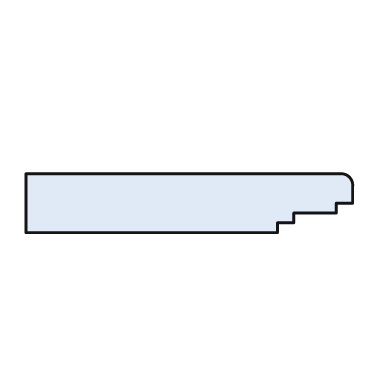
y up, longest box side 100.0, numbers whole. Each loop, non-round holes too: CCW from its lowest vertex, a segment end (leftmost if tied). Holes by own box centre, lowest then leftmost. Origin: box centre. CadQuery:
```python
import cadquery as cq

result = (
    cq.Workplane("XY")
    .moveTo(-50.0, -9.0)
    .lineTo(27.0, -9.0)
    .lineTo(27.0, -6.0)
    .lineTo(32.0, -6.0)
    .lineTo(32.0, -3.0)
    .lineTo(45.0, -3.0)
    .lineTo(45.0, 0.0)
    .lineTo(50.0, 0.0)
    .lineTo(50.0, 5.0)
    .threePointArc((49.0, 8.0), (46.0, 9.0))
    .lineTo(-50.0, 9.0)
    .close()
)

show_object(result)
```